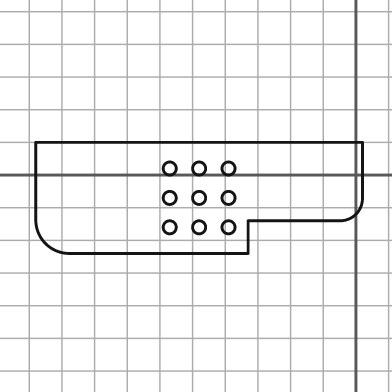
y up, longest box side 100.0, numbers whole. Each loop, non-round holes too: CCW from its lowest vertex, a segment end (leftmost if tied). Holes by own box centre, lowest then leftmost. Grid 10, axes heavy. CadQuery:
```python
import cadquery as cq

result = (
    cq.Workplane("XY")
    .moveTo(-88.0, -24.0)
    .lineTo(-33.0, -24.0)
    .lineTo(-33.0, -14.0)
    .lineTo(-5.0, -14.0)
    .threePointArc((0.0, -12.0), (2.0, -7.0))
    .lineTo(2.0, 10.0)
    .lineTo(-98.0, 10.0)
    .lineTo(-98.0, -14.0)
    .threePointArc((-95.0, -21.0), (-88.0, -24.0))
    .close()
    .moveTo(-57.0, -16.0)
    .circle(2.0)
    .moveTo(-48.0, -16.0)
    .circle(2.0)
    .moveTo(-39.0, -16.0)
    .circle(2.0)
    .moveTo(-57.0, -7.0)
    .circle(2.0)
    .moveTo(-48.0, -7.0)
    .circle(2.0)
    .moveTo(-39.0, -7.0)
    .circle(2.0)
    .moveTo(-57.0, 2.0)
    .circle(2.0)
    .moveTo(-48.0, 2.0)
    .circle(2.0)
    .moveTo(-39.0, 2.0)
    .circle(2.0)
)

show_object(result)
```